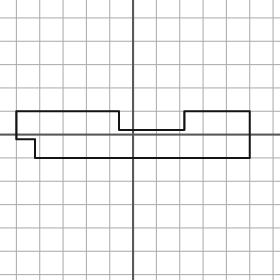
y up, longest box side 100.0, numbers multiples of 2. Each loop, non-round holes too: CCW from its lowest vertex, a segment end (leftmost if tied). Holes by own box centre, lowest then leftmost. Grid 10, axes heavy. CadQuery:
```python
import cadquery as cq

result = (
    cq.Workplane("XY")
    .moveTo(-42.0, -10.0)
    .lineTo(50.0, -10.0)
    .lineTo(50.0, 10.0)
    .lineTo(22.0, 10.0)
    .lineTo(22.0, 2.0)
    .lineTo(-6.0, 2.0)
    .lineTo(-6.0, 10.0)
    .lineTo(-50.0, 10.0)
    .lineTo(-50.0, -2.0)
    .lineTo(-42.0, -2.0)
    .close()
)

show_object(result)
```